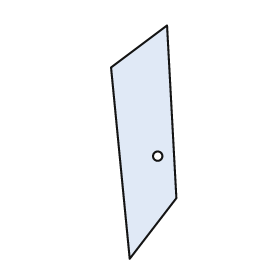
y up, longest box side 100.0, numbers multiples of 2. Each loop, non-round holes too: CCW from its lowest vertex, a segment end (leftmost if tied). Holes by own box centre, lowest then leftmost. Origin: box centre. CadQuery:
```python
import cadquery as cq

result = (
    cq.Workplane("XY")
    .moveTo(-6.0, -50.0)
    .lineTo(14.0, -24.0)
    .lineTo(10.0, 50.0)
    .lineTo(-14.0, 32.0)
    .close()
    .moveTo(6.0, -6.0)
    .circle(2.0)
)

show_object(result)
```